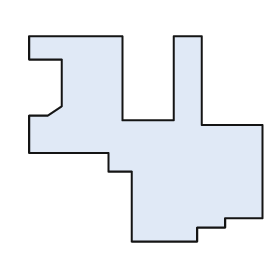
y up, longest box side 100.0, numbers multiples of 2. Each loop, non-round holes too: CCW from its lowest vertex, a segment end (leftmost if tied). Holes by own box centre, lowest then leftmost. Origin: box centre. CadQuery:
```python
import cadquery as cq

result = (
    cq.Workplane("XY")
    .moveTo(-6.0, -44.0)
    .lineTo(22.0, -44.0)
    .lineTo(22.0, -38.0)
    .lineTo(34.0, -38.0)
    .lineTo(34.0, -34.0)
    .lineTo(50.0, -34.0)
    .lineTo(50.0, 6.0)
    .lineTo(24.0, 6.0)
    .lineTo(24.0, 44.0)
    .lineTo(12.0, 44.0)
    .lineTo(12.0, 8.0)
    .lineTo(-10.0, 8.0)
    .lineTo(-10.0, 44.0)
    .lineTo(-50.0, 44.0)
    .lineTo(-50.0, 34.0)
    .lineTo(-36.0, 34.0)
    .lineTo(-36.0, 14.0)
    .lineTo(-42.0, 10.0)
    .lineTo(-50.0, 10.0)
    .lineTo(-50.0, -6.0)
    .lineTo(-16.0, -6.0)
    .lineTo(-16.0, -14.0)
    .lineTo(-6.0, -14.0)
    .close()
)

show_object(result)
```